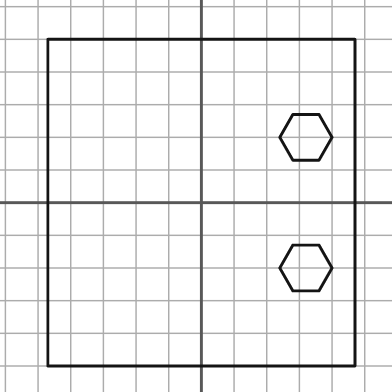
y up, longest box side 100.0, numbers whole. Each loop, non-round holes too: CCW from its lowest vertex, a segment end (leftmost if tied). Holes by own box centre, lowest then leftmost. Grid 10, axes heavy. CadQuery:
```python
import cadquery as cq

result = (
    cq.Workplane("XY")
    .moveTo(-47.0, -50.0)
    .lineTo(47.0, -50.0)
    .lineTo(47.0, 50.0)
    .lineTo(-47.0, 50.0)
    .close()
    .moveTo(28.0, -27.0)
    .lineTo(36.0, -27.0)
    .lineTo(40.0, -20.0)
    .lineTo(36.0, -13.0)
    .lineTo(28.0, -13.0)
    .lineTo(24.0, -20.0)
    .close()
    .moveTo(28.0, 13.0)
    .lineTo(36.0, 13.0)
    .lineTo(40.0, 20.0)
    .lineTo(36.0, 27.0)
    .lineTo(28.0, 27.0)
    .lineTo(24.0, 20.0)
    .close()
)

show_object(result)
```